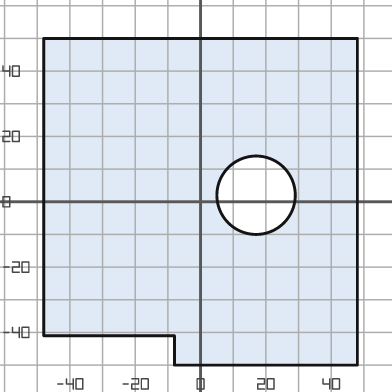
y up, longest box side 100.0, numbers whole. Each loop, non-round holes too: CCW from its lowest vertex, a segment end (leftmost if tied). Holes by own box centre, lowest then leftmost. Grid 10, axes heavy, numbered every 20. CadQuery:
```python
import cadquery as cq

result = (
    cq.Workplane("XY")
    .moveTo(-8.0, -50.0)
    .lineTo(48.0, -50.0)
    .lineTo(48.0, 50.0)
    .lineTo(-48.0, 50.0)
    .lineTo(-48.0, -41.0)
    .lineTo(-8.0, -41.0)
    .close()
    .moveTo(17.0, 2.0)
    .circle(12.0)
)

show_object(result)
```